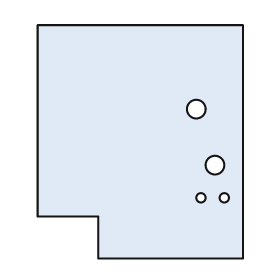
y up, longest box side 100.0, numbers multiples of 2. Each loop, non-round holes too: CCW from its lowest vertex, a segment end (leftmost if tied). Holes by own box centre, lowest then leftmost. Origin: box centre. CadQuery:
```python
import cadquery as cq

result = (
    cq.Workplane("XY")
    .moveTo(-18.0, -50.0)
    .lineTo(44.0, -50.0)
    .lineTo(44.0, 50.0)
    .lineTo(-44.0, 50.0)
    .lineTo(-44.0, -32.0)
    .lineTo(-18.0, -32.0)
    .close()
    .moveTo(26.0, -24.0)
    .circle(2.0)
    .moveTo(36.0, -24.0)
    .circle(2.0)
    .moveTo(32.0, -10.0)
    .circle(4.0)
    .moveTo(24.0, 14.0)
    .circle(4.0)
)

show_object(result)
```